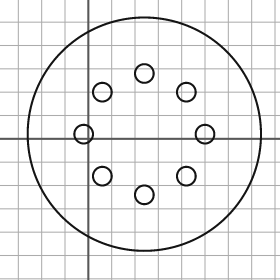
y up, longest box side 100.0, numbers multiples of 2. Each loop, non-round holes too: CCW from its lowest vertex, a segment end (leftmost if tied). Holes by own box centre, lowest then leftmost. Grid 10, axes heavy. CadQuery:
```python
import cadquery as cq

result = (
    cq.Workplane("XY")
    .moveTo(24.0, 2.0)
    .circle(50.0)
    .moveTo(24.0, -24.0)
    .circle(4.0)
    .moveTo(6.0, -16.0)
    .circle(4.0)
    .moveTo(42.0, -16.0)
    .circle(4.0)
    .moveTo(-2.0, 2.0)
    .circle(4.0)
    .moveTo(50.0, 2.0)
    .circle(4.0)
    .moveTo(6.0, 20.0)
    .circle(4.0)
    .moveTo(42.0, 20.0)
    .circle(4.0)
    .moveTo(24.0, 28.0)
    .circle(4.0)
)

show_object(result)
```